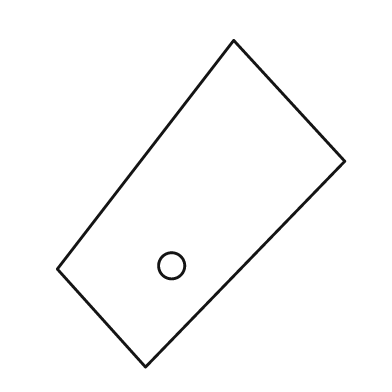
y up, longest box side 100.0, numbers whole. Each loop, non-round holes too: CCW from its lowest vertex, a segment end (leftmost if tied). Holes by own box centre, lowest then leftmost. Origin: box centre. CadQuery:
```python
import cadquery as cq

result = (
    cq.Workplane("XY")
    .moveTo(-17.0, -50.0)
    .lineTo(44.0, 13.0)
    .lineTo(10.0, 50.0)
    .lineTo(-44.0, -20.0)
    .close()
    .moveTo(-9.0, -19.0)
    .circle(4.0)
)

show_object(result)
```